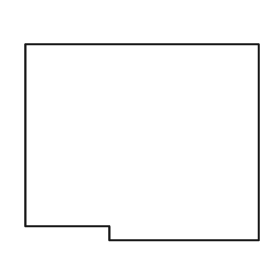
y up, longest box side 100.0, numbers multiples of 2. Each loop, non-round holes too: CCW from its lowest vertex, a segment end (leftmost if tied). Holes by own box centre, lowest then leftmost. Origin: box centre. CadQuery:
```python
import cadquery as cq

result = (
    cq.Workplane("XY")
    .moveTo(-14.0, -42.0)
    .lineTo(50.0, -42.0)
    .lineTo(50.0, 42.0)
    .lineTo(-50.0, 42.0)
    .lineTo(-50.0, -36.0)
    .lineTo(-14.0, -36.0)
    .close()
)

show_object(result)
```